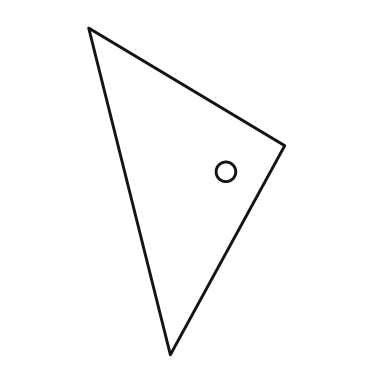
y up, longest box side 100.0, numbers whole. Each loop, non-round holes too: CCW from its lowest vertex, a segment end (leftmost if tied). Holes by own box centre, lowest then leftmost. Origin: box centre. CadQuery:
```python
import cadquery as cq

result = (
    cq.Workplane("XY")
    .moveTo(-5.0, -50.0)
    .lineTo(30.0, 14.0)
    .lineTo(-30.0, 50.0)
    .close()
    .moveTo(12.0, 6.0)
    .circle(3.0)
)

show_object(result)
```